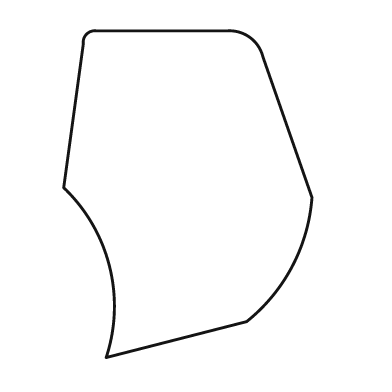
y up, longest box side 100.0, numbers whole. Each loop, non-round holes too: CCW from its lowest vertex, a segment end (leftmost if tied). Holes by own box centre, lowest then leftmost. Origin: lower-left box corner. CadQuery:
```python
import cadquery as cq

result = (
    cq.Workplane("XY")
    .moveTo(13.0, 0.0)
    .lineTo(56.0, 11.0)
    .threePointArc((70.0, 28.0), (76.0, 49.0))
    .lineTo(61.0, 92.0)
    .threePointArc((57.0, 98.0), (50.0, 100.0))
    .lineTo(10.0, 100.0)
    .threePointArc((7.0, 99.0), (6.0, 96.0))
    .lineTo(0.0, 52.0)
    .threePointArc((14.0, 28.0), (13.0, 0.0))
    .close()
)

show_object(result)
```